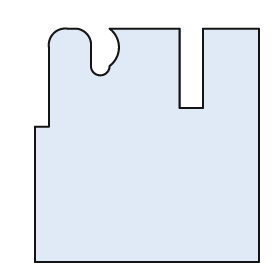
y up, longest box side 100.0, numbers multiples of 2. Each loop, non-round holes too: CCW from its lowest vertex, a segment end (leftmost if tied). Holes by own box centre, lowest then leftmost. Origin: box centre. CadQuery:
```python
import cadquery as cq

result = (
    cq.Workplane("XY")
    .moveTo(-48.0, -50.0)
    .lineTo(48.0, -50.0)
    .lineTo(48.0, 50.0)
    .lineTo(24.0, 50.0)
    .lineTo(24.0, 16.0)
    .lineTo(14.0, 16.0)
    .lineTo(14.0, 50.0)
    .lineTo(-16.0, 50.0)
    .threePointArc((-12.0, 42.0), (-16.0, 34.0))
    .threePointArc((-20.0, 30.0), (-24.0, 34.0))
    .lineTo(-24.0, 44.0)
    .threePointArc((-26.0, 48.0), (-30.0, 50.0))
    .lineTo(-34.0, 50.0)
    .threePointArc((-40.0, 48.0), (-42.0, 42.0))
    .lineTo(-42.0, 8.0)
    .lineTo(-48.0, 8.0)
    .close()
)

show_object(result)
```